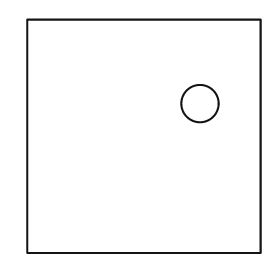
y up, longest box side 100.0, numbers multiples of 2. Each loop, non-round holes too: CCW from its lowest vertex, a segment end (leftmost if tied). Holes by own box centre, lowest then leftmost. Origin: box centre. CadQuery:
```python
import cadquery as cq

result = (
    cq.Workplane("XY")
    .moveTo(-50.0, -50.0)
    .lineTo(50.0, -50.0)
    .lineTo(50.0, 50.0)
    .lineTo(-50.0, 50.0)
    .close()
    .moveTo(24.0, 14.0)
    .circle(8.0)
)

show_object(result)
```